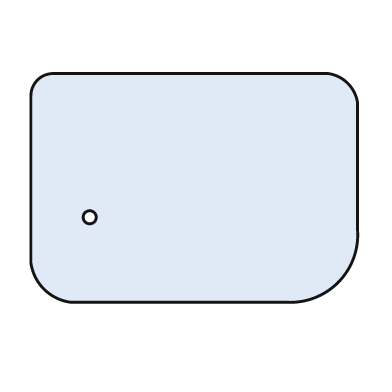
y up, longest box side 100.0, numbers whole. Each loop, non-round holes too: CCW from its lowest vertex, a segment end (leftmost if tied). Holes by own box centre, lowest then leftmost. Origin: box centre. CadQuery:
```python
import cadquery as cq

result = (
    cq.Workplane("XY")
    .moveTo(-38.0, -35.0)
    .lineTo(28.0, -35.0)
    .threePointArc((44.0, -29.0), (50.0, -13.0))
    .lineTo(50.0, 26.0)
    .threePointArc((47.0, 32.0), (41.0, 35.0))
    .lineTo(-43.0, 35.0)
    .threePointArc((-48.0, 33.0), (-50.0, 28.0))
    .lineTo(-50.0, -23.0)
    .threePointArc((-46.0, -31.0), (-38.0, -35.0))
    .close()
    .moveTo(-32.0, -9.0)
    .circle(2.0)
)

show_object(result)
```